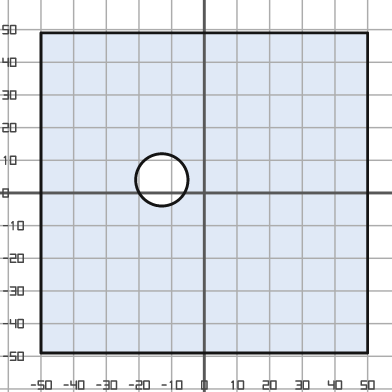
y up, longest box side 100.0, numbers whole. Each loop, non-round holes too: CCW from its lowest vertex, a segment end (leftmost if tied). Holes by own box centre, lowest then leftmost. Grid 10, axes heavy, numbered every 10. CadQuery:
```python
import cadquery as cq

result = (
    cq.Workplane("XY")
    .moveTo(-50.0, -49.0)
    .lineTo(50.0, -49.0)
    .lineTo(50.0, 49.0)
    .lineTo(-50.0, 49.0)
    .close()
    .moveTo(-13.0, 4.0)
    .circle(8.0)
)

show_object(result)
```